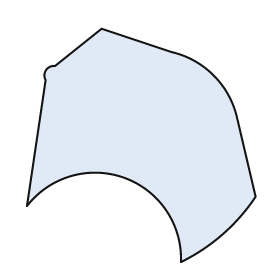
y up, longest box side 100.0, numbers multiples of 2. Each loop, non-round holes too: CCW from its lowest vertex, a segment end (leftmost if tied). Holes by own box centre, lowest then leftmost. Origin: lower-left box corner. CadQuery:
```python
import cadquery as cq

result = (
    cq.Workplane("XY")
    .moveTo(66.0, 0.0)
    .threePointArc((84.0, 12.0), (98.0, 28.0))
    .lineTo(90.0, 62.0)
    .threePointArc((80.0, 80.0), (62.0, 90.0))
    .lineTo(32.0, 100.0)
    .lineTo(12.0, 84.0)
    .threePointArc((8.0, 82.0), (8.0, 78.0))
    .lineTo(0.0, 24.0)
    .threePointArc((42.0, 36.0), (66.0, 0.0))
    .close()
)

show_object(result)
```